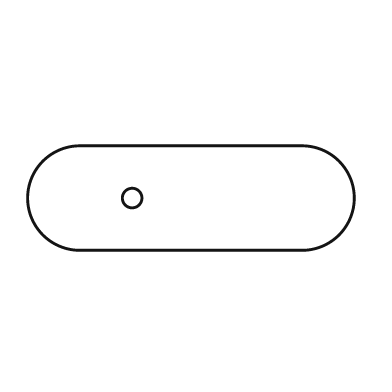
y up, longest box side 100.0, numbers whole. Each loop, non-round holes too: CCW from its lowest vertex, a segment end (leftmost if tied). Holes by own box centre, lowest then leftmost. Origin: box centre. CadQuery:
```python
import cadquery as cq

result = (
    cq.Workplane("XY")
    .moveTo(-34.0, -16.0)
    .lineTo(34.0, -16.0)
    .threePointArc((50.0, 0.0), (34.0, 16.0))
    .lineTo(-34.0, 16.0)
    .threePointArc((-50.0, 0.0), (-34.0, -16.0))
    .close()
    .moveTo(-18.0, 0.0)
    .circle(3.0)
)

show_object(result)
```